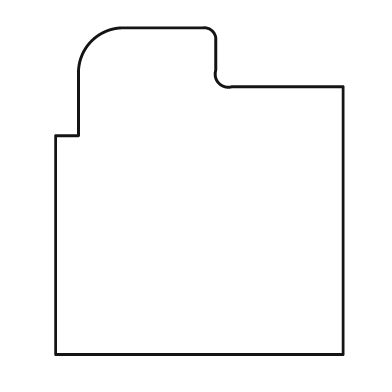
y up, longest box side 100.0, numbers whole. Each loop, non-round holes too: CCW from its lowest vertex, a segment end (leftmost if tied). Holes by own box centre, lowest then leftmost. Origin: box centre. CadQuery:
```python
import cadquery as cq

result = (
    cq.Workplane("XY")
    .moveTo(-44.0, -50.0)
    .lineTo(44.0, -50.0)
    .lineTo(44.0, 32.0)
    .lineTo(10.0, 32.0)
    .threePointArc((6.0, 33.0), (5.0, 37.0))
    .lineTo(5.0, 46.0)
    .threePointArc((4.0, 49.0), (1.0, 50.0))
    .lineTo(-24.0, 50.0)
    .threePointArc((-33.0, 46.0), (-37.0, 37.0))
    .lineTo(-37.0, 17.0)
    .lineTo(-44.0, 17.0)
    .close()
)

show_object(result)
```